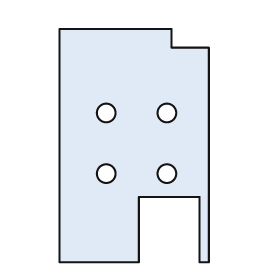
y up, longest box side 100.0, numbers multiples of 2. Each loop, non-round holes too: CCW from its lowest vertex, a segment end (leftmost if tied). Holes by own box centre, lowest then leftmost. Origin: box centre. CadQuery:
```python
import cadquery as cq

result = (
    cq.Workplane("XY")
    .moveTo(-32.0, -50.0)
    .lineTo(2.0, -50.0)
    .lineTo(2.0, -22.0)
    .lineTo(28.0, -22.0)
    .lineTo(28.0, -50.0)
    .lineTo(32.0, -50.0)
    .lineTo(32.0, 42.0)
    .lineTo(16.0, 42.0)
    .lineTo(16.0, 50.0)
    .lineTo(-32.0, 50.0)
    .close()
    .moveTo(-12.0, -12.0)
    .circle(4.0)
    .moveTo(14.0, -12.0)
    .circle(4.0)
    .moveTo(-12.0, 14.0)
    .circle(4.0)
    .moveTo(14.0, 14.0)
    .circle(4.0)
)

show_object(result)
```